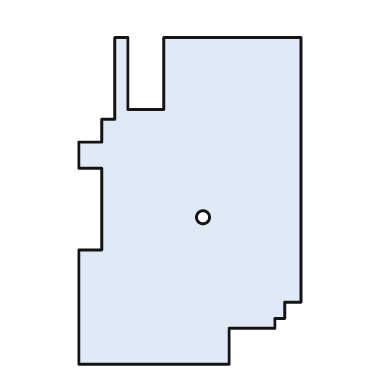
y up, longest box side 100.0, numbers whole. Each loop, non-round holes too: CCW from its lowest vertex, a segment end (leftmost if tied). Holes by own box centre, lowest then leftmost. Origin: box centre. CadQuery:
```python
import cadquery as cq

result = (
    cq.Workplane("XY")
    .moveTo(-34.0, -50.0)
    .lineTo(12.0, -50.0)
    .lineTo(12.0, -39.0)
    .lineTo(26.0, -39.0)
    .lineTo(26.0, -36.0)
    .lineTo(29.0, -36.0)
    .lineTo(29.0, -31.0)
    .lineTo(34.0, -31.0)
    .lineTo(34.0, 50.0)
    .lineTo(-8.0, 50.0)
    .lineTo(-8.0, 28.0)
    .lineTo(-19.0, 28.0)
    .lineTo(-19.0, 50.0)
    .lineTo(-23.0, 50.0)
    .lineTo(-23.0, 25.0)
    .lineTo(-27.0, 25.0)
    .lineTo(-27.0, 18.0)
    .lineTo(-34.0, 18.0)
    .lineTo(-34.0, 10.0)
    .lineTo(-27.0, 10.0)
    .lineTo(-27.0, -15.0)
    .lineTo(-34.0, -15.0)
    .close()
    .moveTo(4.0, -5.0)
    .circle(2.0)
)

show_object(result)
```